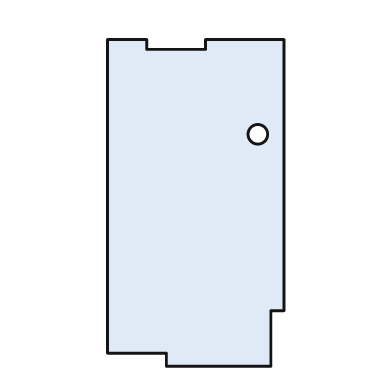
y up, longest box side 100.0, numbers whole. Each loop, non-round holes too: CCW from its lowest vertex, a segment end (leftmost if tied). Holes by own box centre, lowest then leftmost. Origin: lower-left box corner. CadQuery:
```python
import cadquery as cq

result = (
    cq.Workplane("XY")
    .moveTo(18.0, 0.0)
    .lineTo(50.0, 0.0)
    .lineTo(50.0, 17.0)
    .lineTo(54.0, 17.0)
    .lineTo(54.0, 100.0)
    .lineTo(30.0, 100.0)
    .lineTo(30.0, 97.0)
    .lineTo(12.0, 97.0)
    .lineTo(12.0, 100.0)
    .lineTo(0.0, 100.0)
    .lineTo(0.0, 4.0)
    .lineTo(18.0, 4.0)
    .close()
    .moveTo(46.0, 71.0)
    .circle(3.0)
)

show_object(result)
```